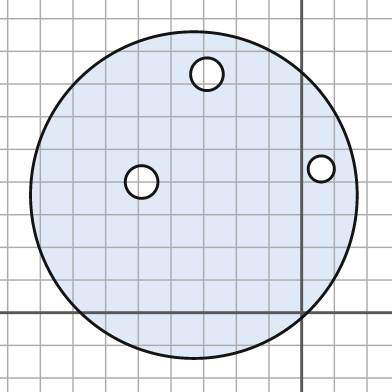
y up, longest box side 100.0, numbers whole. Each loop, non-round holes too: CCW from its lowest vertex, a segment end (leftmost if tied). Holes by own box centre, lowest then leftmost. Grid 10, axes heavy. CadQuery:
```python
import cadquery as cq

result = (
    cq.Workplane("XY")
    .moveTo(-33.0, 36.0)
    .circle(50.0)
    .moveTo(-49.0, 40.0)
    .circle(5.0)
    .moveTo(6.0, 44.0)
    .circle(4.0)
    .moveTo(-29.0, 73.0)
    .circle(5.0)
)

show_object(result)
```